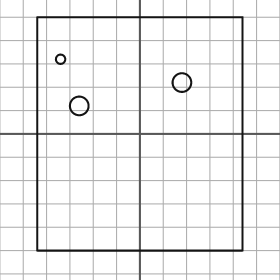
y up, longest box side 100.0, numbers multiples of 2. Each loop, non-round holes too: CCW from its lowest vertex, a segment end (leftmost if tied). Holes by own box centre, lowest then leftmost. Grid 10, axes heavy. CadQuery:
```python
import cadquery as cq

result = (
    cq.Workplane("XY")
    .moveTo(-44.0, -50.0)
    .lineTo(44.0, -50.0)
    .lineTo(44.0, 50.0)
    .lineTo(-44.0, 50.0)
    .close()
    .moveTo(-26.0, 12.0)
    .circle(4.0)
    .moveTo(18.0, 22.0)
    .circle(4.0)
    .moveTo(-34.0, 32.0)
    .circle(2.0)
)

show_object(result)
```